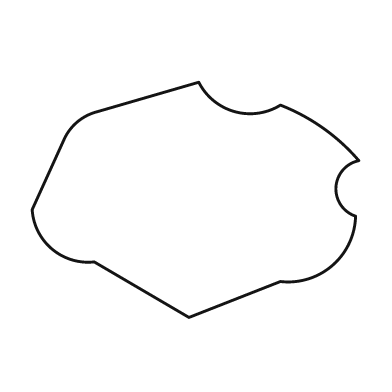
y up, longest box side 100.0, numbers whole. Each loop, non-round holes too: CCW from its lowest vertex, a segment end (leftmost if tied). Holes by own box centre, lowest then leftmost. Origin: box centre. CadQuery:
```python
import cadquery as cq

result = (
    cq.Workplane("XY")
    .moveTo(-2.0, -36.0)
    .lineTo(26.0, -25.0)
    .threePointArc((42.0, -20.0), (49.0, -5.0))
    .threePointArc((43.0, 4.0), (50.0, 12.0))
    .threePointArc((39.0, 22.0), (26.0, 29.0))
    .threePointArc((12.0, 27.0), (1.0, 36.0))
    .lineTo(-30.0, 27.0)
    .threePointArc((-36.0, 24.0), (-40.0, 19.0))
    .lineTo(-50.0, -3.0)
    .threePointArc((-44.0, -15.0), (-31.0, -19.0))
    .close()
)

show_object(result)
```